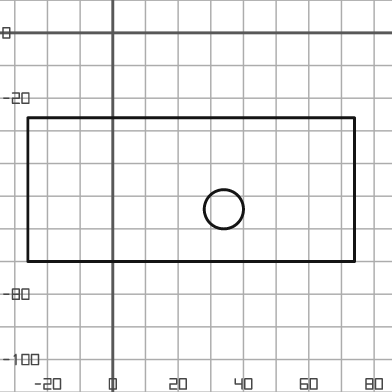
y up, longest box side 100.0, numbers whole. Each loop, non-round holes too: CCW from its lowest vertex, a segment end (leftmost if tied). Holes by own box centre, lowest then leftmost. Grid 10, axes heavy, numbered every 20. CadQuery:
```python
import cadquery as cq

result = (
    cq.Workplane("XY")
    .moveTo(-26.0, -70.0)
    .lineTo(74.0, -70.0)
    .lineTo(74.0, -26.0)
    .lineTo(-26.0, -26.0)
    .close()
    .moveTo(34.0, -54.0)
    .circle(6.0)
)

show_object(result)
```